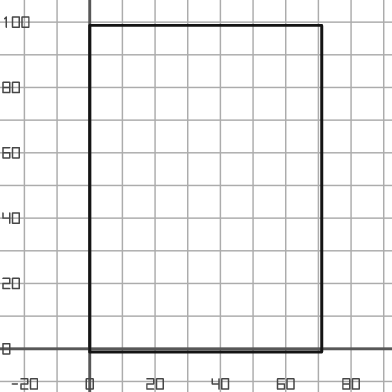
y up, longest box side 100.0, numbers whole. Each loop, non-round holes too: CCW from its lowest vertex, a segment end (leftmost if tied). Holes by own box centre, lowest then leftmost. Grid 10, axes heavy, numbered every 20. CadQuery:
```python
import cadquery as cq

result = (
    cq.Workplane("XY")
    .moveTo(0.0, -1.0)
    .lineTo(71.0, -1.0)
    .lineTo(71.0, 99.0)
    .lineTo(0.0, 99.0)
    .close()
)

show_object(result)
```